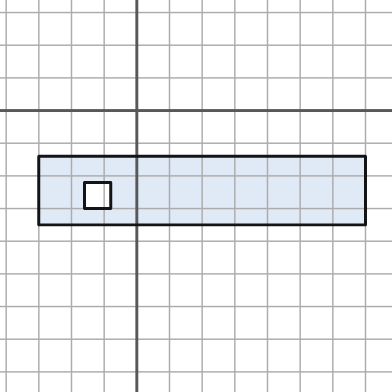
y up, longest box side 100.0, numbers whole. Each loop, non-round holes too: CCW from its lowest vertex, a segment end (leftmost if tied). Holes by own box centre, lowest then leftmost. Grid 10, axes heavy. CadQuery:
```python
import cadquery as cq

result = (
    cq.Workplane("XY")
    .moveTo(-30.0, -35.0)
    .lineTo(70.0, -35.0)
    .lineTo(70.0, -14.0)
    .lineTo(-30.0, -14.0)
    .close()
    .moveTo(-16.0, -30.0)
    .lineTo(-8.0, -30.0)
    .lineTo(-8.0, -22.0)
    .lineTo(-16.0, -22.0)
    .close()
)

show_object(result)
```